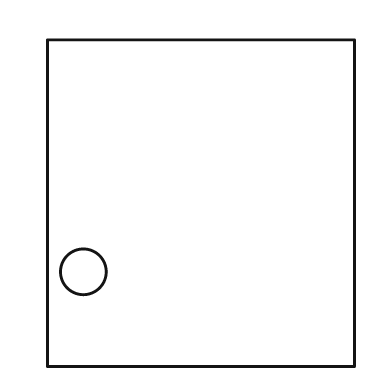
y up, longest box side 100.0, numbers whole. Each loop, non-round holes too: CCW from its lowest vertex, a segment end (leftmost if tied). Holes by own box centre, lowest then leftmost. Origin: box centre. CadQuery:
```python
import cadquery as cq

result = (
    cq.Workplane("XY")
    .moveTo(-47.0, -50.0)
    .lineTo(47.0, -50.0)
    .lineTo(47.0, 50.0)
    .lineTo(-47.0, 50.0)
    .close()
    .moveTo(-36.0, -21.0)
    .circle(7.0)
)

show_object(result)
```